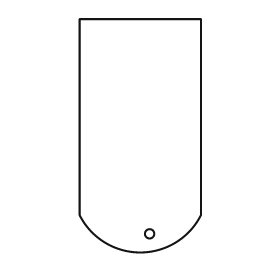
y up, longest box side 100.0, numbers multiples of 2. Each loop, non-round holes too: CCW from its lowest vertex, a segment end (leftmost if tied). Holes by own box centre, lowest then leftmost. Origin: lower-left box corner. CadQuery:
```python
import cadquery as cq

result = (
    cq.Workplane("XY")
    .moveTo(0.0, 16.0)
    .threePointArc((26.0, 0.0), (52.0, 16.0))
    .lineTo(52.0, 100.0)
    .lineTo(0.0, 100.0)
    .close()
    .moveTo(30.0, 8.0)
    .circle(2.0)
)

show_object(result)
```